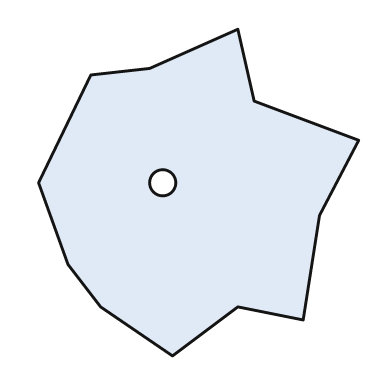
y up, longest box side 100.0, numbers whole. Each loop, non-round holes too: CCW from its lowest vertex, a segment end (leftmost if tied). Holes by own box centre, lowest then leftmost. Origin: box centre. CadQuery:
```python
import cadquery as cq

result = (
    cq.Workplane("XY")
    .moveTo(-8.0, -50.0)
    .lineTo(12.0, -35.0)
    .lineTo(32.0, -39.0)
    .lineTo(37.0, -7.0)
    .lineTo(49.0, 16.0)
    .lineTo(17.0, 28.0)
    .lineTo(12.0, 50.0)
    .lineTo(-15.0, 38.0)
    .lineTo(-33.0, 36.0)
    .lineTo(-49.0, 3.0)
    .lineTo(-40.0, -22.0)
    .lineTo(-30.0, -35.0)
    .close()
    .moveTo(-11.0, 3.0)
    .circle(4.0)
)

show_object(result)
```